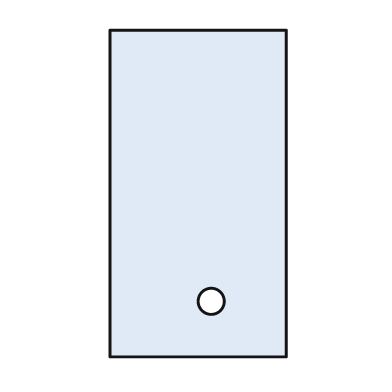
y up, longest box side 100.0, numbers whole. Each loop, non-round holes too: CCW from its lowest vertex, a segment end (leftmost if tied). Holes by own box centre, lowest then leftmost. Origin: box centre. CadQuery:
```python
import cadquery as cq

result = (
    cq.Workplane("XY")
    .moveTo(-27.0, -50.0)
    .lineTo(27.0, -50.0)
    .lineTo(27.0, 50.0)
    .lineTo(-27.0, 50.0)
    .close()
    .moveTo(4.0, -33.0)
    .circle(4.0)
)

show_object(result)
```